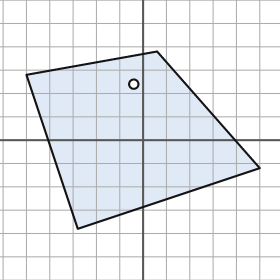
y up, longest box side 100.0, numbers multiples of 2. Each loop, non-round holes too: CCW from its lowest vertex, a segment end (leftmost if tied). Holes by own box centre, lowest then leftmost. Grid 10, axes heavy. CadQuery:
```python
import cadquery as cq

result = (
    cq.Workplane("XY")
    .moveTo(-28.0, -38.0)
    .lineTo(50.0, -12.0)
    .lineTo(6.0, 38.0)
    .lineTo(-50.0, 28.0)
    .close()
    .moveTo(-4.0, 24.0)
    .circle(2.0)
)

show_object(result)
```